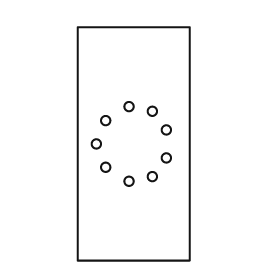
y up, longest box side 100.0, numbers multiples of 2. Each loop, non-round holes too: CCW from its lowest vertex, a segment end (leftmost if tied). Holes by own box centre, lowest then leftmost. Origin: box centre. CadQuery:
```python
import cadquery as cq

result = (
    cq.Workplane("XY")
    .moveTo(-24.0, -50.0)
    .lineTo(24.0, -50.0)
    .lineTo(24.0, 50.0)
    .lineTo(-24.0, 50.0)
    .close()
    .moveTo(-2.0, -16.0)
    .circle(2.0)
    .moveTo(8.0, -14.0)
    .circle(2.0)
    .moveTo(-12.0, -10.0)
    .circle(2.0)
    .moveTo(14.0, -6.0)
    .circle(2.0)
    .moveTo(-16.0, 0.0)
    .circle(2.0)
    .moveTo(14.0, 6.0)
    .circle(2.0)
    .moveTo(-12.0, 10.0)
    .circle(2.0)
    .moveTo(8.0, 14.0)
    .circle(2.0)
    .moveTo(-2.0, 16.0)
    .circle(2.0)
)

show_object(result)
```